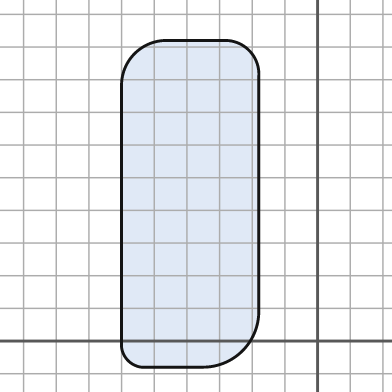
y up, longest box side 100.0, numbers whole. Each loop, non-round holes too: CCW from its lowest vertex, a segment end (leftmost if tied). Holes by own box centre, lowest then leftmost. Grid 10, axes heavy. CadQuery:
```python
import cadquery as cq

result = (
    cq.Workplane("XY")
    .moveTo(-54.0, -8.0)
    .lineTo(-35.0, -8.0)
    .threePointArc((-23.0, -3.0), (-18.0, 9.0))
    .lineTo(-18.0, 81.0)
    .threePointArc((-21.0, 89.0), (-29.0, 92.0))
    .lineTo(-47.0, 92.0)
    .threePointArc((-56.0, 88.0), (-60.0, 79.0))
    .lineTo(-60.0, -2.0)
    .threePointArc((-58.0, -6.0), (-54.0, -8.0))
    .close()
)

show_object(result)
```